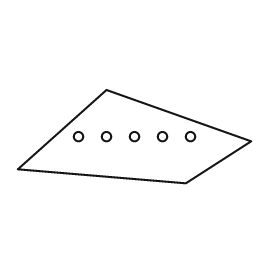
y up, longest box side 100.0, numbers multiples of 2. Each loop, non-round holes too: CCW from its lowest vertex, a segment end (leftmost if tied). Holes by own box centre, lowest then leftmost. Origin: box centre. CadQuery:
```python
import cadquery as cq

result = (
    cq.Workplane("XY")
    .moveTo(22.0, -20.0)
    .lineTo(50.0, -2.0)
    .lineTo(-12.0, 20.0)
    .lineTo(-50.0, -14.0)
    .close()
    .moveTo(-24.0, 0.0)
    .circle(2.0)
    .moveTo(-12.0, 0.0)
    .circle(2.0)
    .moveTo(0.0, 0.0)
    .circle(2.0)
    .moveTo(12.0, 0.0)
    .circle(2.0)
    .moveTo(24.0, 0.0)
    .circle(2.0)
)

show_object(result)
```